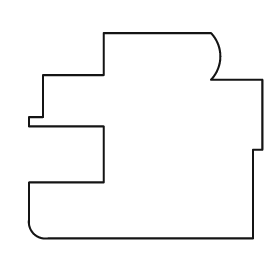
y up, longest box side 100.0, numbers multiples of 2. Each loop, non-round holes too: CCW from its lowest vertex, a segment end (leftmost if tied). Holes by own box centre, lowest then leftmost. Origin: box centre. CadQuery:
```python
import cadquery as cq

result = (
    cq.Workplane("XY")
    .moveTo(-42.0, -44.0)
    .lineTo(46.0, -44.0)
    .lineTo(46.0, -6.0)
    .lineTo(50.0, -6.0)
    .lineTo(50.0, 24.0)
    .lineTo(28.0, 24.0)
    .threePointArc((32.0, 34.0), (28.0, 44.0))
    .lineTo(-18.0, 44.0)
    .lineTo(-18.0, 26.0)
    .lineTo(-44.0, 26.0)
    .lineTo(-44.0, 8.0)
    .lineTo(-50.0, 8.0)
    .lineTo(-50.0, 4.0)
    .lineTo(-18.0, 4.0)
    .lineTo(-18.0, -20.0)
    .lineTo(-50.0, -20.0)
    .lineTo(-50.0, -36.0)
    .threePointArc((-48.0, -42.0), (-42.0, -44.0))
    .close()
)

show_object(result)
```